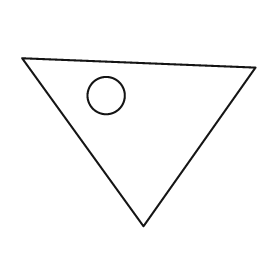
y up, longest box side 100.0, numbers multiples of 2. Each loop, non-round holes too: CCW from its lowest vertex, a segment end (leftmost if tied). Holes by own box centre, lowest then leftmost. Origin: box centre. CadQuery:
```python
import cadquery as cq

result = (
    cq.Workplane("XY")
    .moveTo(2.0, -36.0)
    .lineTo(50.0, 32.0)
    .lineTo(-50.0, 36.0)
    .close()
    .moveTo(-14.0, 20.0)
    .circle(8.0)
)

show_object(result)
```